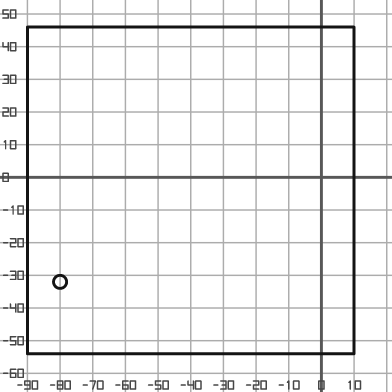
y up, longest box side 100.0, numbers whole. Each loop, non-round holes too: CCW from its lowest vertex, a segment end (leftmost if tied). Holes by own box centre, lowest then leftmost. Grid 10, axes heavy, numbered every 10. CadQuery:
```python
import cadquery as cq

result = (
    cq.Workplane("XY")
    .moveTo(-90.0, -54.0)
    .lineTo(10.0, -54.0)
    .lineTo(10.0, 46.0)
    .lineTo(-90.0, 46.0)
    .close()
    .moveTo(-80.0, -32.0)
    .circle(2.0)
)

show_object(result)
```